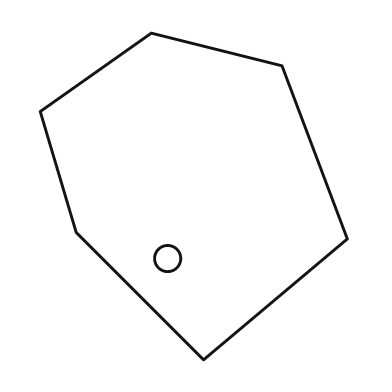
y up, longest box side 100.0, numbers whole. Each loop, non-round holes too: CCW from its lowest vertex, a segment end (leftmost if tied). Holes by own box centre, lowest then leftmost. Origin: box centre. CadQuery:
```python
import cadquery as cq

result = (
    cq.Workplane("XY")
    .moveTo(3.0, -50.0)
    .lineTo(47.0, -13.0)
    .lineTo(27.0, 40.0)
    .lineTo(-13.0, 50.0)
    .lineTo(-47.0, 26.0)
    .lineTo(-36.0, -11.0)
    .close()
    .moveTo(-8.0, -19.0)
    .circle(4.0)
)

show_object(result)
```